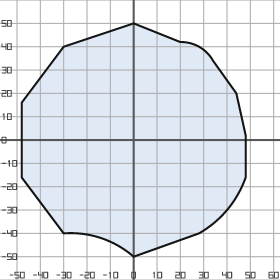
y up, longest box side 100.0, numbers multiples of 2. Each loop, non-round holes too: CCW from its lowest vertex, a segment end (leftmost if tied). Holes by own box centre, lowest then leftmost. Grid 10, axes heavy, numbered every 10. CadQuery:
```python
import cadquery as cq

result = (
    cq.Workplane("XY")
    .moveTo(0.0, -50.0)
    .lineTo(28.0, -40.0)
    .threePointArc((40.0, -30.0), (48.0, -16.0))
    .lineTo(48.0, 2.0)
    .lineTo(44.0, 20.0)
    .lineTo(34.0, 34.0)
    .threePointArc((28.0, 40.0), (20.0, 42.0))
    .lineTo(0.0, 50.0)
    .lineTo(-30.0, 40.0)
    .lineTo(-48.0, 16.0)
    .lineTo(-48.0, -16.0)
    .lineTo(-30.0, -40.0)
    .threePointArc((-14.0, -42.0), (0.0, -50.0))
    .close()
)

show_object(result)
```